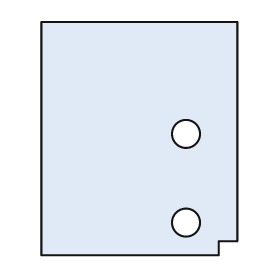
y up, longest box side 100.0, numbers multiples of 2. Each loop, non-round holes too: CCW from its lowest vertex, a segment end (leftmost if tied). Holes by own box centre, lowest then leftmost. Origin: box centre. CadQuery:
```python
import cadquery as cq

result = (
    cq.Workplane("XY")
    .moveTo(-42.0, -50.0)
    .lineTo(34.0, -50.0)
    .lineTo(34.0, -44.0)
    .lineTo(42.0, -44.0)
    .lineTo(42.0, 50.0)
    .lineTo(-42.0, 50.0)
    .close()
    .moveTo(20.0, -36.0)
    .circle(6.0)
    .moveTo(20.0, 2.0)
    .circle(6.0)
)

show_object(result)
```